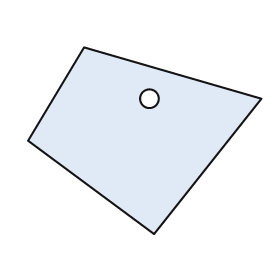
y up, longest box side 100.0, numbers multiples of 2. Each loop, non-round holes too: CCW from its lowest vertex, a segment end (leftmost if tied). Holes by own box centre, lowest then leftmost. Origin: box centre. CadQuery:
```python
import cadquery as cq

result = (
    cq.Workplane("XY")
    .moveTo(4.0, -40.0)
    .lineTo(50.0, 18.0)
    .lineTo(-26.0, 40.0)
    .lineTo(-50.0, 0.0)
    .close()
    .moveTo(2.0, 18.0)
    .circle(4.0)
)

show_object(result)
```